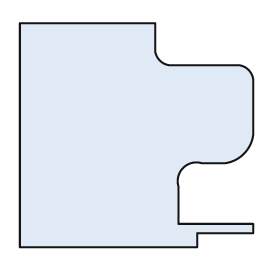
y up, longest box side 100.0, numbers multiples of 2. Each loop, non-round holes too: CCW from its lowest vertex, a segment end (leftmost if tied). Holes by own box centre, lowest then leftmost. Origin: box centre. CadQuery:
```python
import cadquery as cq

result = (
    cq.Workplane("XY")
    .moveTo(-50.0, -48.0)
    .lineTo(26.0, -48.0)
    .lineTo(26.0, -42.0)
    .lineTo(50.0, -42.0)
    .lineTo(50.0, -38.0)
    .lineTo(18.0, -38.0)
    .lineTo(18.0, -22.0)
    .threePointArc((20.0, -14.0), (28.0, -12.0))
    .lineTo(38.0, -12.0)
    .threePointArc((46.0, -8.0), (50.0, 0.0))
    .lineTo(50.0, 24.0)
    .threePointArc((48.0, 28.0), (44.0, 30.0))
    .lineTo(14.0, 30.0)
    .threePointArc((10.0, 32.0), (8.0, 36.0))
    .lineTo(8.0, 48.0)
    .lineTo(-50.0, 48.0)
    .close()
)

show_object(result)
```